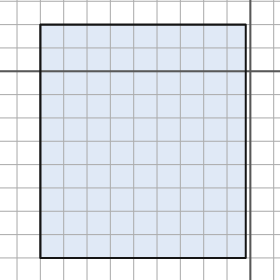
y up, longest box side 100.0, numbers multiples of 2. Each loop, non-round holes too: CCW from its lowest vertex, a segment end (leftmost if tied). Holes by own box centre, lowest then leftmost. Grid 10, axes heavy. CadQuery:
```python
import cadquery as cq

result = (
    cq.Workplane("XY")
    .moveTo(-90.0, -80.0)
    .lineTo(-2.0, -80.0)
    .lineTo(-2.0, 20.0)
    .lineTo(-90.0, 20.0)
    .close()
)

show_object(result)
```